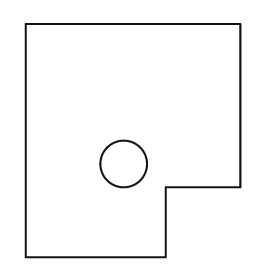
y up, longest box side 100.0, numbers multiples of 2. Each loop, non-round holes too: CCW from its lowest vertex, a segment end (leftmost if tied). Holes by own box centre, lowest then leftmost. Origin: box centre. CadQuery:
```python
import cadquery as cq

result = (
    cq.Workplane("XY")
    .moveTo(-46.0, -50.0)
    .lineTo(14.0, -50.0)
    .lineTo(14.0, -20.0)
    .lineTo(46.0, -20.0)
    .lineTo(46.0, 50.0)
    .lineTo(-46.0, 50.0)
    .close()
    .moveTo(-4.0, -10.0)
    .circle(10.0)
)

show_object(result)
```